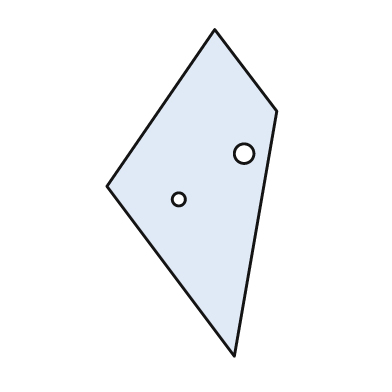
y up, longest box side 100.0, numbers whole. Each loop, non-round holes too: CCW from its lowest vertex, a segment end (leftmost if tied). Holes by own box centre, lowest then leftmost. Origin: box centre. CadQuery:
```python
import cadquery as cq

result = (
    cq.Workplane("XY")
    .moveTo(13.0, -50.0)
    .lineTo(26.0, 25.0)
    .lineTo(7.0, 50.0)
    .lineTo(-26.0, 2.0)
    .close()
    .moveTo(-4.0, -2.0)
    .circle(2.0)
    .moveTo(16.0, 12.0)
    .circle(3.0)
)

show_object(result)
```